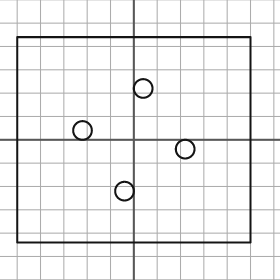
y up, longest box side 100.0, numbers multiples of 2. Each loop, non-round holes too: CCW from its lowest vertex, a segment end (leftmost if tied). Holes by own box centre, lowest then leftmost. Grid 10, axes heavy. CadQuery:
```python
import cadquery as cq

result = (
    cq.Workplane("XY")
    .moveTo(-50.0, -44.0)
    .lineTo(50.0, -44.0)
    .lineTo(50.0, 44.0)
    .lineTo(-50.0, 44.0)
    .close()
    .moveTo(-4.0, -22.0)
    .circle(4.0)
    .moveTo(22.0, -4.0)
    .circle(4.0)
    .moveTo(-22.0, 4.0)
    .circle(4.0)
    .moveTo(4.0, 22.0)
    .circle(4.0)
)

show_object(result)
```